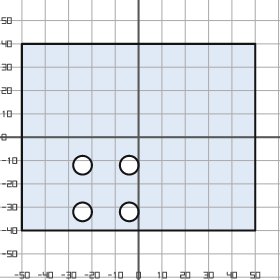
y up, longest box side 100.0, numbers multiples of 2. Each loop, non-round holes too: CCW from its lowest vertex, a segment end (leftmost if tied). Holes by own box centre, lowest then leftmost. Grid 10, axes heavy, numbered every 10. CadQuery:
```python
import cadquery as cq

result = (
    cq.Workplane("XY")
    .moveTo(-50.0, -40.0)
    .lineTo(50.0, -40.0)
    .lineTo(50.0, 40.0)
    .lineTo(-50.0, 40.0)
    .close()
    .moveTo(-24.0, -32.0)
    .circle(4.0)
    .moveTo(-4.0, -32.0)
    .circle(4.0)
    .moveTo(-24.0, -12.0)
    .circle(4.0)
    .moveTo(-4.0, -12.0)
    .circle(4.0)
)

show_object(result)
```